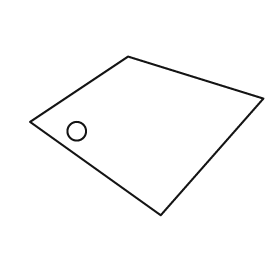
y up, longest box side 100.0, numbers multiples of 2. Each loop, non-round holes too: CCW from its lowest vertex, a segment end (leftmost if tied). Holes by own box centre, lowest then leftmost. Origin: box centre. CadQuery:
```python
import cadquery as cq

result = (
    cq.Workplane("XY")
    .moveTo(6.0, -34.0)
    .lineTo(50.0, 16.0)
    .lineTo(-8.0, 34.0)
    .lineTo(-50.0, 6.0)
    .close()
    .moveTo(-30.0, 2.0)
    .circle(4.0)
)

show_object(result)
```